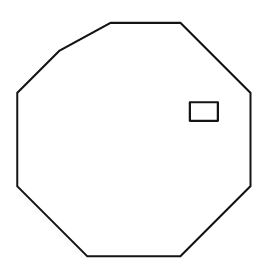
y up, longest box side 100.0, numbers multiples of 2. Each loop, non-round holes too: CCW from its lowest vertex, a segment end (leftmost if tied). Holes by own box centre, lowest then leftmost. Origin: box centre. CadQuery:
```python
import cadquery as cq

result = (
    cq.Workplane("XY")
    .moveTo(-20.0, -50.0)
    .lineTo(20.0, -50.0)
    .lineTo(50.0, -20.0)
    .lineTo(50.0, 20.0)
    .lineTo(20.0, 50.0)
    .lineTo(-10.0, 50.0)
    .lineTo(-32.0, 38.0)
    .lineTo(-50.0, 20.0)
    .lineTo(-50.0, -20.0)
    .close()
    .moveTo(24.0, 8.0)
    .lineTo(36.0, 8.0)
    .lineTo(36.0, 16.0)
    .lineTo(24.0, 16.0)
    .close()
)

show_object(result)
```